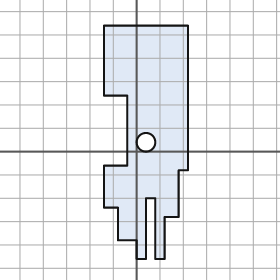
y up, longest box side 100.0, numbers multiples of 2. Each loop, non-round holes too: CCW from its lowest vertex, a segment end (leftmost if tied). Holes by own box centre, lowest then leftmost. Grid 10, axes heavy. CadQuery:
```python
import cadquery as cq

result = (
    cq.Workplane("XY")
    .moveTo(0.0, -46.0)
    .lineTo(4.0, -46.0)
    .lineTo(4.0, -20.0)
    .lineTo(8.0, -20.0)
    .lineTo(8.0, -46.0)
    .lineTo(12.0, -46.0)
    .lineTo(12.0, -28.0)
    .lineTo(18.0, -28.0)
    .lineTo(18.0, -8.0)
    .lineTo(22.0, -8.0)
    .lineTo(22.0, 54.0)
    .lineTo(-14.0, 54.0)
    .lineTo(-14.0, 24.0)
    .lineTo(-4.0, 24.0)
    .lineTo(-4.0, -6.0)
    .lineTo(-14.0, -6.0)
    .lineTo(-14.0, -24.0)
    .lineTo(-8.0, -24.0)
    .lineTo(-8.0, -38.0)
    .lineTo(0.0, -38.0)
    .close()
    .moveTo(4.0, 4.0)
    .circle(4.0)
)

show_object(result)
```